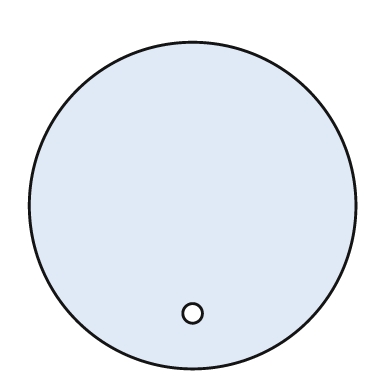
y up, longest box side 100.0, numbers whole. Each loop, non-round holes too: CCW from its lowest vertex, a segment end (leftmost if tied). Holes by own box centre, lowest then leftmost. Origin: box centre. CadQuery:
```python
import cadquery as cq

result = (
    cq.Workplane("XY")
    .moveTo(0.0, 0.0)
    .circle(50.0)
    .moveTo(0.0, -33.0)
    .circle(3.0)
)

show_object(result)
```